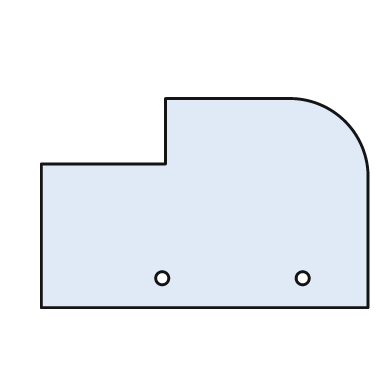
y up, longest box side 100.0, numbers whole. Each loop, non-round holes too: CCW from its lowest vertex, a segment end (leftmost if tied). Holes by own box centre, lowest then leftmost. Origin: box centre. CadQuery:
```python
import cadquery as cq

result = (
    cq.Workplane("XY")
    .moveTo(-50.0, -32.0)
    .lineTo(50.0, -32.0)
    .lineTo(50.0, 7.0)
    .threePointArc((43.0, 25.0), (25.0, 32.0))
    .lineTo(-12.0, 32.0)
    .lineTo(-12.0, 12.0)
    .lineTo(-50.0, 12.0)
    .close()
    .moveTo(-13.0, -23.0)
    .circle(2.0)
    .moveTo(30.0, -23.0)
    .circle(2.0)
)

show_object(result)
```